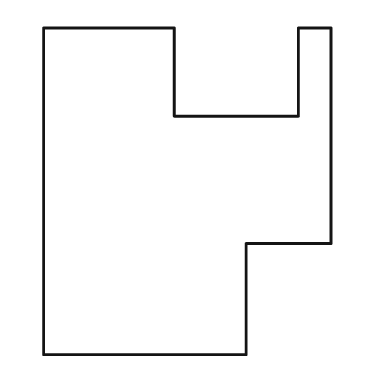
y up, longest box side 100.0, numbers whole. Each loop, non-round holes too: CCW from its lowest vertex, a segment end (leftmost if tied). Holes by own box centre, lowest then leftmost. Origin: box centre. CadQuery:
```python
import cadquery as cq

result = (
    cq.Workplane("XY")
    .moveTo(-44.0, -50.0)
    .lineTo(18.0, -50.0)
    .lineTo(18.0, -16.0)
    .lineTo(44.0, -16.0)
    .lineTo(44.0, 50.0)
    .lineTo(34.0, 50.0)
    .lineTo(34.0, 23.0)
    .lineTo(-4.0, 23.0)
    .lineTo(-4.0, 50.0)
    .lineTo(-44.0, 50.0)
    .close()
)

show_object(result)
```